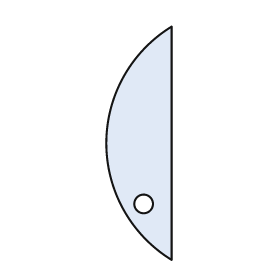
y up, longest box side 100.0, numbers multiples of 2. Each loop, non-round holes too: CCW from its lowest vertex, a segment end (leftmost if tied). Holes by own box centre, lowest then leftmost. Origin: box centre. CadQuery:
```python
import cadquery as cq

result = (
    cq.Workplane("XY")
    .moveTo(14.0, -50.0)
    .lineTo(14.0, 50.0)
    .threePointArc((-14.0, 0.0), (14.0, -50.0))
    .close()
    .moveTo(2.0, -26.0)
    .circle(4.0)
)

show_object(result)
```